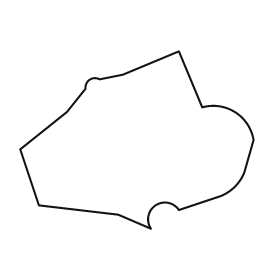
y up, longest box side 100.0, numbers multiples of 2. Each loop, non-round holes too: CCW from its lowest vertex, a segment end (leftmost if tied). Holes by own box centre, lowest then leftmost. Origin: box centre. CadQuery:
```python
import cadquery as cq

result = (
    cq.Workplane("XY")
    .moveTo(6.0, -38.0)
    .threePointArc((8.0, -28.0), (18.0, -30.0))
    .lineTo(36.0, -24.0)
    .threePointArc((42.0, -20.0), (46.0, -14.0))
    .lineTo(50.0, 0.0)
    .threePointArc((42.0, 12.0), (28.0, 14.0))
    .lineTo(18.0, 38.0)
    .lineTo(-6.0, 28.0)
    .lineTo(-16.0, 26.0)
    .threePointArc((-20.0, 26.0), (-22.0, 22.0))
    .lineTo(-30.0, 12.0)
    .lineTo(-50.0, -4.0)
    .lineTo(-42.0, -28.0)
    .lineTo(-8.0, -32.0)
    .close()
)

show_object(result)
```